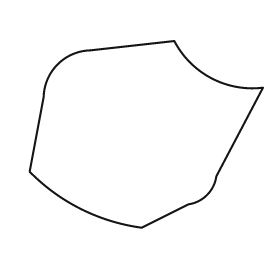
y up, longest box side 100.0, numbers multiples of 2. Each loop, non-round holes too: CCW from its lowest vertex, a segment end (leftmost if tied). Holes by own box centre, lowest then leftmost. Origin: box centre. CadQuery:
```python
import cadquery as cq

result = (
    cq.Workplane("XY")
    .moveTo(-2.0, -40.0)
    .lineTo(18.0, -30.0)
    .threePointArc((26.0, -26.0), (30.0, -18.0))
    .lineTo(50.0, 20.0)
    .threePointArc((28.0, 24.0), (12.0, 40.0))
    .lineTo(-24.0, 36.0)
    .threePointArc((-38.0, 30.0), (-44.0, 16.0))
    .lineTo(-50.0, -16.0)
    .threePointArc((-28.0, -32.0), (-2.0, -40.0))
    .close()
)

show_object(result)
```